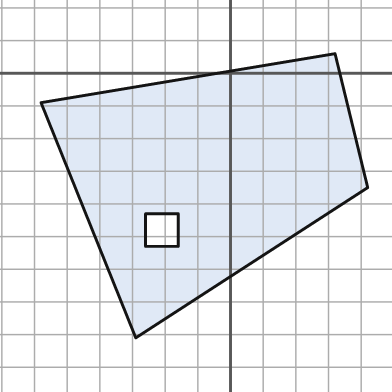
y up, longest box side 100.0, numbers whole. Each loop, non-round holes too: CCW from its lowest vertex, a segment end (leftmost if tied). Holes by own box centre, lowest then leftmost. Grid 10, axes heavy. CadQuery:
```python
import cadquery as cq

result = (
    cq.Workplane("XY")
    .moveTo(-29.0, -81.0)
    .lineTo(42.0, -35.0)
    .lineTo(32.0, 6.0)
    .lineTo(-58.0, -9.0)
    .close()
    .moveTo(-26.0, -53.0)
    .lineTo(-16.0, -53.0)
    .lineTo(-16.0, -43.0)
    .lineTo(-26.0, -43.0)
    .close()
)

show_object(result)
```